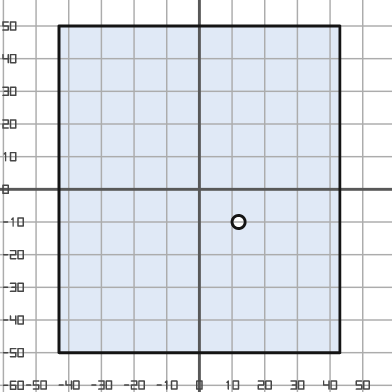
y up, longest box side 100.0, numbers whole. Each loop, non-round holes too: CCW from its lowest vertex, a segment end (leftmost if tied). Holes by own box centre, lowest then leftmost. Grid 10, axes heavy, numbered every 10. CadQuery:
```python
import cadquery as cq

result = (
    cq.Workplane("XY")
    .moveTo(-43.0, -50.0)
    .lineTo(43.0, -50.0)
    .lineTo(43.0, 50.0)
    .lineTo(-43.0, 50.0)
    .close()
    .moveTo(12.0, -10.0)
    .circle(2.0)
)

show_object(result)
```